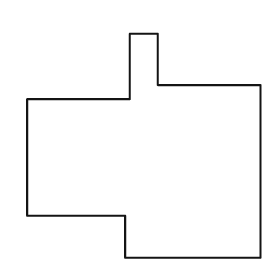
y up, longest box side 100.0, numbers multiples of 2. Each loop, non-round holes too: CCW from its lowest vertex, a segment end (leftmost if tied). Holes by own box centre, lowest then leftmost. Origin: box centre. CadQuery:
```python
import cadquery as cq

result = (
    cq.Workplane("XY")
    .moveTo(-8.0, -48.0)
    .lineTo(50.0, -48.0)
    .lineTo(50.0, 26.0)
    .lineTo(6.0, 26.0)
    .lineTo(6.0, 48.0)
    .lineTo(-6.0, 48.0)
    .lineTo(-6.0, 20.0)
    .lineTo(-50.0, 20.0)
    .lineTo(-50.0, -30.0)
    .lineTo(-8.0, -30.0)
    .close()
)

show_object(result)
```